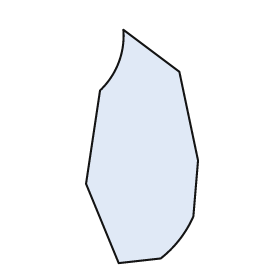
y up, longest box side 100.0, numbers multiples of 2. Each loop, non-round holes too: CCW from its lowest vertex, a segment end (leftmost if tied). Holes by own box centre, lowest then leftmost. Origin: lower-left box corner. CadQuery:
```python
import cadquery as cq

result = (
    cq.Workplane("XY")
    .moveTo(14.0, 0.0)
    .lineTo(32.0, 2.0)
    .threePointArc((40.0, 10.0), (46.0, 20.0))
    .lineTo(48.0, 44.0)
    .lineTo(40.0, 82.0)
    .lineTo(16.0, 100.0)
    .threePointArc((14.0, 86.0), (6.0, 74.0))
    .lineTo(0.0, 34.0)
    .close()
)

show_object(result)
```